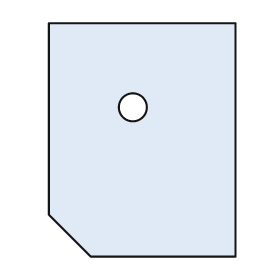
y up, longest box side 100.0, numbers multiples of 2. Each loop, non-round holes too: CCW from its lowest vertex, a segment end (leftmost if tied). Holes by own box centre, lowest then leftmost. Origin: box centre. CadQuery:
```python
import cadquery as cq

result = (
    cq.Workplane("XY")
    .moveTo(-22.0, -50.0)
    .lineTo(40.0, -50.0)
    .lineTo(40.0, 50.0)
    .lineTo(-40.0, 50.0)
    .lineTo(-40.0, -32.0)
    .close()
    .moveTo(-4.0, 14.0)
    .circle(6.0)
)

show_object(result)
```